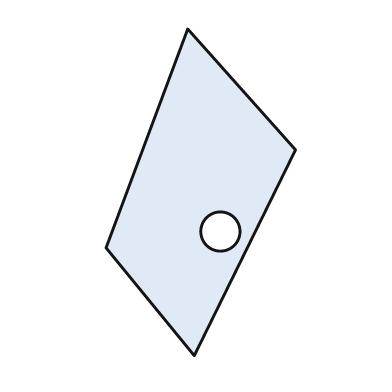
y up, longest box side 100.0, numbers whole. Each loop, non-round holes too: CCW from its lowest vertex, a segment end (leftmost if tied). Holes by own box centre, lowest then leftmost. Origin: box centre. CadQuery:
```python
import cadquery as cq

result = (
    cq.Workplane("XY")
    .moveTo(-2.0, -50.0)
    .lineTo(29.0, 13.0)
    .lineTo(-4.0, 50.0)
    .lineTo(-29.0, -17.0)
    .close()
    .moveTo(6.0, -12.0)
    .circle(6.0)
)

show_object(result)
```